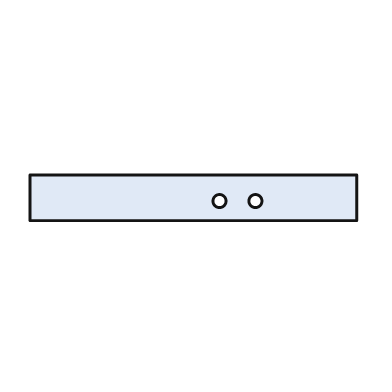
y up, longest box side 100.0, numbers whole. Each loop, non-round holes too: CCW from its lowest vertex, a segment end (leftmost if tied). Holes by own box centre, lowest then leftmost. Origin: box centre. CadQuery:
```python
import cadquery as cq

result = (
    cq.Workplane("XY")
    .moveTo(-50.0, -7.0)
    .lineTo(50.0, -7.0)
    .lineTo(50.0, 7.0)
    .lineTo(-50.0, 7.0)
    .close()
    .moveTo(8.0, -1.0)
    .circle(2.0)
    .moveTo(19.0, -1.0)
    .circle(2.0)
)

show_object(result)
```